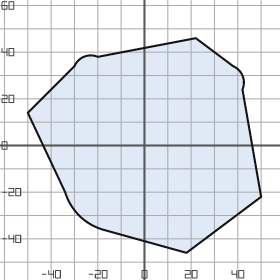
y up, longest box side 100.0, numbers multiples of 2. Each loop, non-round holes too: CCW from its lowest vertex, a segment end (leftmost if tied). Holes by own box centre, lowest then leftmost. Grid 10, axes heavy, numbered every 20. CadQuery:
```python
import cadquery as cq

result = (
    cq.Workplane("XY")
    .moveTo(18.0, -46.0)
    .lineTo(50.0, -22.0)
    .lineTo(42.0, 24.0)
    .threePointArc((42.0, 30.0), (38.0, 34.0))
    .lineTo(22.0, 46.0)
    .lineTo(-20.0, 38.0)
    .threePointArc((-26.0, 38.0), (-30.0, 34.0))
    .lineTo(-50.0, 14.0)
    .lineTo(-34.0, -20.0)
    .threePointArc((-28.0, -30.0), (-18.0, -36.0))
    .close()
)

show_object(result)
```